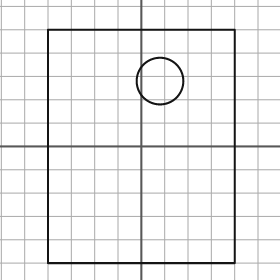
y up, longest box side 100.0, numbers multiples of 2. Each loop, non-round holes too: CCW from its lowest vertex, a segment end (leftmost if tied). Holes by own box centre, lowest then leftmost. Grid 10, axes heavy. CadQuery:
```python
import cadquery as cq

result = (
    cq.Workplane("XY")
    .moveTo(-40.0, -50.0)
    .lineTo(40.0, -50.0)
    .lineTo(40.0, 50.0)
    .lineTo(-40.0, 50.0)
    .close()
    .moveTo(8.0, 28.0)
    .circle(10.0)
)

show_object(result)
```